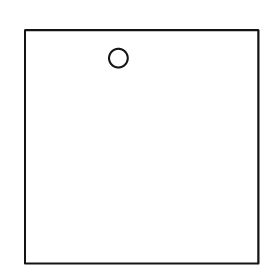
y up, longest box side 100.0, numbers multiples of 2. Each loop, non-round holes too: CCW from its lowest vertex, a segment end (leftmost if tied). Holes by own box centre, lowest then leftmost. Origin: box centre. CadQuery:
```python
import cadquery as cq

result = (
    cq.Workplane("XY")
    .moveTo(-50.0, -50.0)
    .lineTo(50.0, -50.0)
    .lineTo(50.0, 50.0)
    .lineTo(-50.0, 50.0)
    .close()
    .moveTo(-10.0, 38.0)
    .circle(4.0)
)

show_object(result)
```